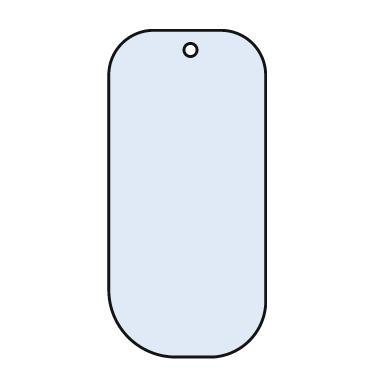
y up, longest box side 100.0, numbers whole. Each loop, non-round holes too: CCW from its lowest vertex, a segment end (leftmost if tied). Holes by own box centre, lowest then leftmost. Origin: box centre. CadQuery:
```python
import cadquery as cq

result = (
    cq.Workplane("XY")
    .moveTo(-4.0, -50.0)
    .lineTo(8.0, -50.0)
    .threePointArc((19.0, -45.0), (24.0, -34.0))
    .lineTo(24.0, 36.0)
    .threePointArc((20.0, 46.0), (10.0, 50.0))
    .lineTo(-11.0, 50.0)
    .threePointArc((-20.0, 46.0), (-24.0, 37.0))
    .lineTo(-24.0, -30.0)
    .threePointArc((-18.0, -44.0), (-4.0, -50.0))
    .close()
    .moveTo(1.0, 44.0)
    .circle(2.0)
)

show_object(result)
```